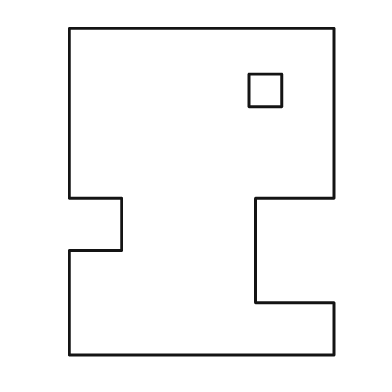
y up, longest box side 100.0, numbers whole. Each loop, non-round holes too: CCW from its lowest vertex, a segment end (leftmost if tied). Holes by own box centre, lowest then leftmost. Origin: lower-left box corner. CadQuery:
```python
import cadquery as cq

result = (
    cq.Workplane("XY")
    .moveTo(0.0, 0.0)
    .lineTo(81.0, 0.0)
    .lineTo(81.0, 16.0)
    .lineTo(57.0, 16.0)
    .lineTo(57.0, 48.0)
    .lineTo(81.0, 48.0)
    .lineTo(81.0, 100.0)
    .lineTo(0.0, 100.0)
    .lineTo(0.0, 48.0)
    .lineTo(16.0, 48.0)
    .lineTo(16.0, 32.0)
    .lineTo(0.0, 32.0)
    .close()
    .moveTo(55.0, 76.0)
    .lineTo(65.0, 76.0)
    .lineTo(65.0, 86.0)
    .lineTo(55.0, 86.0)
    .close()
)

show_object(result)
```